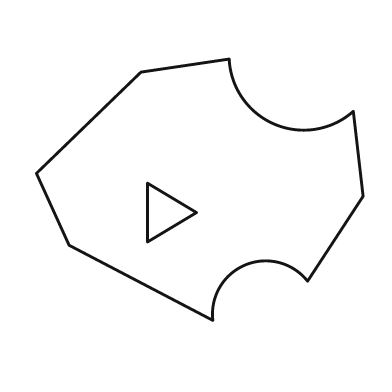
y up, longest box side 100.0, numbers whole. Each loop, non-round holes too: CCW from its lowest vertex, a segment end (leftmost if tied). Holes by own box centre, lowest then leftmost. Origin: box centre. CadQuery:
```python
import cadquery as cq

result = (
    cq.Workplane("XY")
    .moveTo(4.0, -40.0)
    .threePointArc((14.0, -23.0), (33.0, -28.0))
    .lineTo(50.0, -2.0)
    .lineTo(47.0, 24.0)
    .threePointArc((23.0, 20.0), (9.0, 40.0))
    .lineTo(-18.0, 36.0)
    .lineTo(-50.0, 5.0)
    .lineTo(-40.0, -17.0)
    .close()
    .moveTo(-16.0, -16.0)
    .lineTo(-1.0, -7.0)
    .lineTo(-16.0, 2.0)
    .close()
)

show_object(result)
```